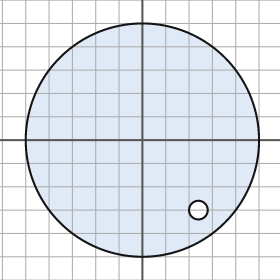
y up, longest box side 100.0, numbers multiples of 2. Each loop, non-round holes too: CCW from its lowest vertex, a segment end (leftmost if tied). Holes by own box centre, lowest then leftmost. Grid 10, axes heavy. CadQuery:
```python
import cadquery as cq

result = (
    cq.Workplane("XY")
    .moveTo(0.0, 0.0)
    .circle(50.0)
    .moveTo(24.0, -30.0)
    .circle(4.0)
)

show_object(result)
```